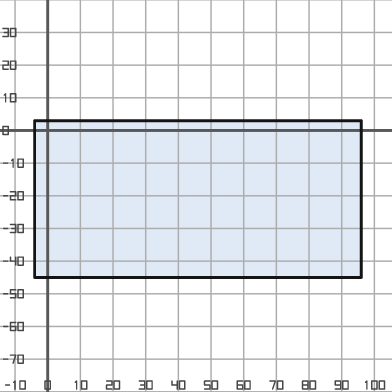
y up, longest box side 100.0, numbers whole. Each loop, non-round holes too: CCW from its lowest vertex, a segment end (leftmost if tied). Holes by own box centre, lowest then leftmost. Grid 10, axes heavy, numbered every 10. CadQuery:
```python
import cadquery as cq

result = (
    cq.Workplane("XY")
    .moveTo(-4.0, -45.0)
    .lineTo(96.0, -45.0)
    .lineTo(96.0, 3.0)
    .lineTo(-4.0, 3.0)
    .close()
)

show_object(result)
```